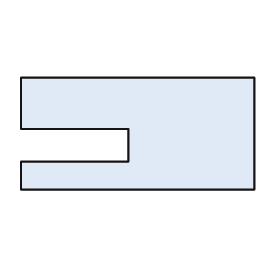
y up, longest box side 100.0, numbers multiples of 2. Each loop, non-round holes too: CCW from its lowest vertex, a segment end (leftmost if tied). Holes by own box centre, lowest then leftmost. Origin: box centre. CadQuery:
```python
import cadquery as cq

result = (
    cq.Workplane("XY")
    .moveTo(-50.0, -24.0)
    .lineTo(50.0, -24.0)
    .lineTo(50.0, 24.0)
    .lineTo(-50.0, 24.0)
    .lineTo(-50.0, 2.0)
    .lineTo(-4.0, 2.0)
    .lineTo(-4.0, -12.0)
    .lineTo(-50.0, -12.0)
    .close()
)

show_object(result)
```